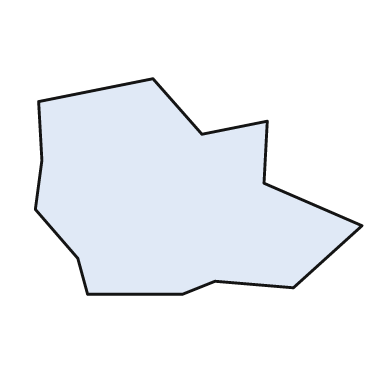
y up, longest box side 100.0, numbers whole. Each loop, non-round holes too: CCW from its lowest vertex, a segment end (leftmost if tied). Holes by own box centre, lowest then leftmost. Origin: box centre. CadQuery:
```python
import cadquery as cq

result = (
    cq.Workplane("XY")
    .moveTo(-34.0, -33.0)
    .lineTo(-5.0, -33.0)
    .lineTo(5.0, -29.0)
    .lineTo(29.0, -31.0)
    .lineTo(50.0, -12.0)
    .lineTo(20.0, 1.0)
    .lineTo(21.0, 20.0)
    .lineTo(1.0, 16.0)
    .lineTo(-14.0, 33.0)
    .lineTo(-49.0, 26.0)
    .lineTo(-48.0, 8.0)
    .lineTo(-50.0, -7.0)
    .lineTo(-37.0, -22.0)
    .close()
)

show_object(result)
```